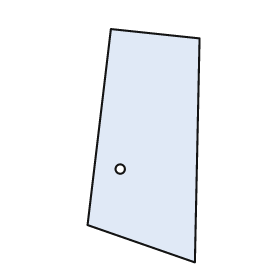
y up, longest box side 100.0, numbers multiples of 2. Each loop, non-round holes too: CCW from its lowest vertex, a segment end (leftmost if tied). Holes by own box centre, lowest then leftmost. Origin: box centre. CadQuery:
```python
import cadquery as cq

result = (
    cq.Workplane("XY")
    .moveTo(22.0, -50.0)
    .lineTo(24.0, 46.0)
    .lineTo(-14.0, 50.0)
    .lineTo(-24.0, -34.0)
    .close()
    .moveTo(-10.0, -10.0)
    .circle(2.0)
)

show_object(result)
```